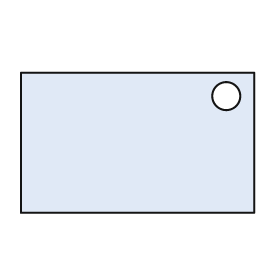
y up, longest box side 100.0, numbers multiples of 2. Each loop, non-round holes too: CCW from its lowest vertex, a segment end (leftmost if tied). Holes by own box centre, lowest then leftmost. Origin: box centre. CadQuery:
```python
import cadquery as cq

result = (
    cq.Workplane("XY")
    .moveTo(-50.0, -30.0)
    .lineTo(50.0, -30.0)
    .lineTo(50.0, 30.0)
    .lineTo(-50.0, 30.0)
    .close()
    .moveTo(38.0, 20.0)
    .circle(6.0)
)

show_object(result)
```